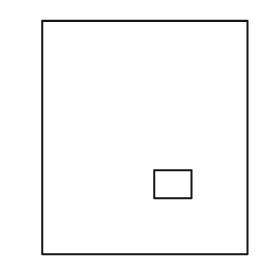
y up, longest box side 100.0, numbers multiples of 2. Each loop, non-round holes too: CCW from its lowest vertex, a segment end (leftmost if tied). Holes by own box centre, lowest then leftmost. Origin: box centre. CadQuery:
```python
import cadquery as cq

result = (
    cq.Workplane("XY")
    .moveTo(-44.0, -50.0)
    .lineTo(44.0, -50.0)
    .lineTo(44.0, 50.0)
    .lineTo(-44.0, 50.0)
    .close()
    .moveTo(4.0, -26.0)
    .lineTo(20.0, -26.0)
    .lineTo(20.0, -14.0)
    .lineTo(4.0, -14.0)
    .close()
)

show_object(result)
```